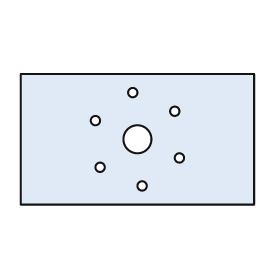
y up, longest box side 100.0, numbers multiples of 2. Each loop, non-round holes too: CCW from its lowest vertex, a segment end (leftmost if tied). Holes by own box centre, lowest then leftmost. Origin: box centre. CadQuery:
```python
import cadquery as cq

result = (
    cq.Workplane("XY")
    .moveTo(-50.0, -28.0)
    .lineTo(50.0, -28.0)
    .lineTo(50.0, 28.0)
    .lineTo(-50.0, 28.0)
    .close()
    .moveTo(2.0, -20.0)
    .circle(2.0)
    .moveTo(-16.0, -12.0)
    .circle(2.0)
    .moveTo(18.0, -8.0)
    .circle(2.0)
    .moveTo(0.0, 0.0)
    .circle(6.0)
    .moveTo(-18.0, 8.0)
    .circle(2.0)
    .moveTo(16.0, 12.0)
    .circle(2.0)
    .moveTo(-2.0, 20.0)
    .circle(2.0)
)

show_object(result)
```